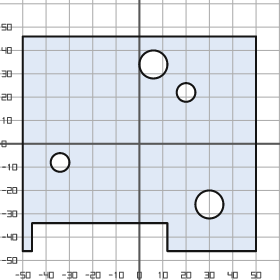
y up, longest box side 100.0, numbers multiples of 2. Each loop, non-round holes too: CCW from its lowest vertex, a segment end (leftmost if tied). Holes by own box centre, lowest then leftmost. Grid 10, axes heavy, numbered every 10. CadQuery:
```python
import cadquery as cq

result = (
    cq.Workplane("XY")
    .moveTo(-50.0, -46.0)
    .lineTo(-46.0, -46.0)
    .lineTo(-46.0, -34.0)
    .lineTo(12.0, -34.0)
    .lineTo(12.0, -46.0)
    .lineTo(50.0, -46.0)
    .lineTo(50.0, 46.0)
    .lineTo(-50.0, 46.0)
    .close()
    .moveTo(30.0, -26.0)
    .circle(6.0)
    .moveTo(-34.0, -8.0)
    .circle(4.0)
    .moveTo(20.0, 22.0)
    .circle(4.0)
    .moveTo(6.0, 34.0)
    .circle(6.0)
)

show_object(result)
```